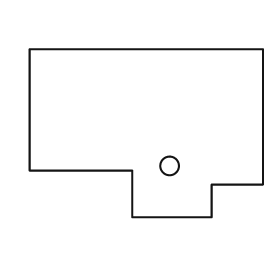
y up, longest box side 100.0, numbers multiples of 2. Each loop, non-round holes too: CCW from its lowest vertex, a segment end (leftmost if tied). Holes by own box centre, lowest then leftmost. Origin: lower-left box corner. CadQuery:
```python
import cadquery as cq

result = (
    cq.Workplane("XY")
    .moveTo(44.0, 0.0)
    .lineTo(78.0, 0.0)
    .lineTo(78.0, 14.0)
    .lineTo(100.0, 14.0)
    .lineTo(100.0, 72.0)
    .lineTo(0.0, 72.0)
    .lineTo(0.0, 20.0)
    .lineTo(44.0, 20.0)
    .close()
    .moveTo(60.0, 22.0)
    .circle(4.0)
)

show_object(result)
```